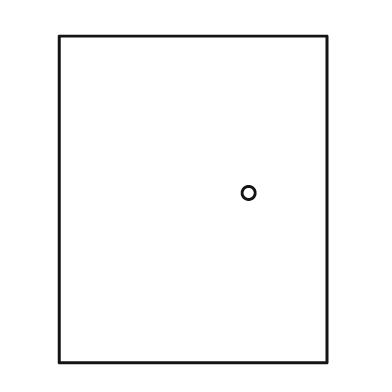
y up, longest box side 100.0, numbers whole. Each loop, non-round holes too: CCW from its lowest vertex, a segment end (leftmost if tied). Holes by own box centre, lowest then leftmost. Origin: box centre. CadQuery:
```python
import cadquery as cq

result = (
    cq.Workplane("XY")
    .moveTo(-41.0, -50.0)
    .lineTo(41.0, -50.0)
    .lineTo(41.0, 50.0)
    .lineTo(-41.0, 50.0)
    .close()
    .moveTo(17.0, 2.0)
    .circle(2.0)
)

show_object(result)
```